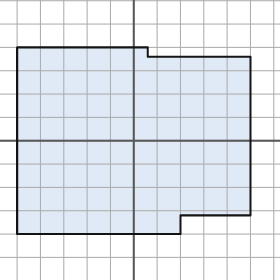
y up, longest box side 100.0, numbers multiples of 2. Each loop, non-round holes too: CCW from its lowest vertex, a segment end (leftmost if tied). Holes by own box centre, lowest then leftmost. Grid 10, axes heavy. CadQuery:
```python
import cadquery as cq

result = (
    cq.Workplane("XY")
    .moveTo(-50.0, -40.0)
    .lineTo(20.0, -40.0)
    .lineTo(20.0, -32.0)
    .lineTo(50.0, -32.0)
    .lineTo(50.0, 36.0)
    .lineTo(6.0, 36.0)
    .lineTo(6.0, 40.0)
    .lineTo(-50.0, 40.0)
    .close()
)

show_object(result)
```